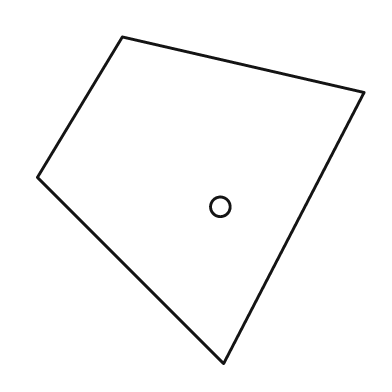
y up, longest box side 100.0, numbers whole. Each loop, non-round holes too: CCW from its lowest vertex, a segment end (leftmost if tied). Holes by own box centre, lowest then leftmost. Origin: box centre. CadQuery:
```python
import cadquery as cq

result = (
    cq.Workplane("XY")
    .moveTo(7.0, -50.0)
    .lineTo(50.0, 33.0)
    .lineTo(-24.0, 50.0)
    .lineTo(-50.0, 7.0)
    .close()
    .moveTo(6.0, -2.0)
    .circle(3.0)
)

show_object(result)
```